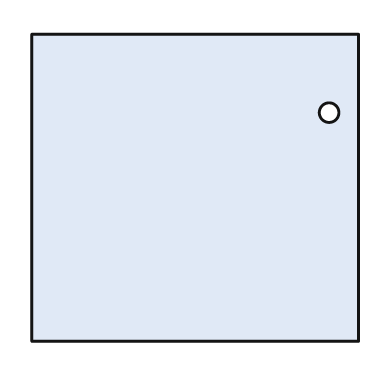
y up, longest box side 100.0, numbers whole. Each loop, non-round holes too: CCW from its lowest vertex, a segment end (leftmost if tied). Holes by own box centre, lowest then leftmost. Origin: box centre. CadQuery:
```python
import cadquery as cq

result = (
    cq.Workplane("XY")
    .moveTo(-50.0, -47.0)
    .lineTo(50.0, -47.0)
    .lineTo(50.0, 47.0)
    .lineTo(-50.0, 47.0)
    .close()
    .moveTo(41.0, 23.0)
    .circle(3.0)
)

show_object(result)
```